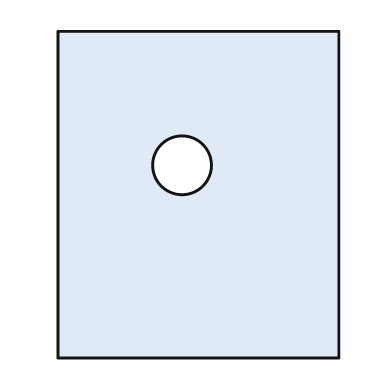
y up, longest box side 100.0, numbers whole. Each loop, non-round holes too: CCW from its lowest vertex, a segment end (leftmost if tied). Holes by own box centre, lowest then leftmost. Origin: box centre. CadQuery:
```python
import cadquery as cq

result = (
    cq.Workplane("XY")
    .moveTo(-43.0, -50.0)
    .lineTo(43.0, -50.0)
    .lineTo(43.0, 50.0)
    .lineTo(-43.0, 50.0)
    .close()
    .moveTo(-5.0, 9.0)
    .circle(9.0)
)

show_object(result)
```